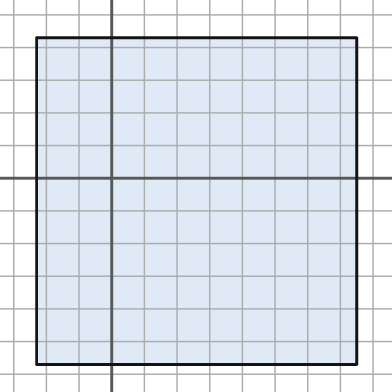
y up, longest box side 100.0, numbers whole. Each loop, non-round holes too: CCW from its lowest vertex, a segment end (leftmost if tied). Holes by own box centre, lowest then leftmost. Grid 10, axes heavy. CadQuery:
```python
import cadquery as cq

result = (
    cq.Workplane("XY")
    .moveTo(-23.0, -57.0)
    .lineTo(75.0, -57.0)
    .lineTo(75.0, 43.0)
    .lineTo(-23.0, 43.0)
    .close()
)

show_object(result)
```